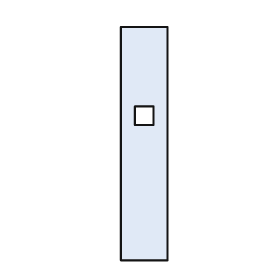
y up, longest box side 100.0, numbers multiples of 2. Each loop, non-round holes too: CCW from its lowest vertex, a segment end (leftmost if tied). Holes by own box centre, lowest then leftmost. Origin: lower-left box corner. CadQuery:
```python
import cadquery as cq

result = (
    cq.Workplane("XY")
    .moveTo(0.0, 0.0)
    .lineTo(20.0, 0.0)
    .lineTo(20.0, 100.0)
    .lineTo(0.0, 100.0)
    .close()
    .moveTo(6.0, 58.0)
    .lineTo(14.0, 58.0)
    .lineTo(14.0, 66.0)
    .lineTo(6.0, 66.0)
    .close()
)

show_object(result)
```